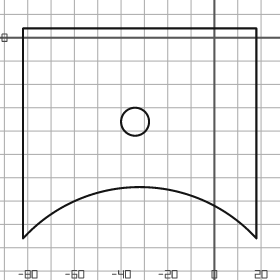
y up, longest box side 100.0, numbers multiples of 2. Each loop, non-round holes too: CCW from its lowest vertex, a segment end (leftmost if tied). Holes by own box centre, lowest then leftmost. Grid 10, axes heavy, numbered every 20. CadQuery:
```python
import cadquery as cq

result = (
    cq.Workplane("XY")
    .moveTo(-82.0, -86.0)
    .threePointArc((-32.0, -64.0), (18.0, -86.0))
    .lineTo(18.0, 4.0)
    .lineTo(-82.0, 4.0)
    .close()
    .moveTo(-34.0, -36.0)
    .circle(6.0)
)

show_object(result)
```